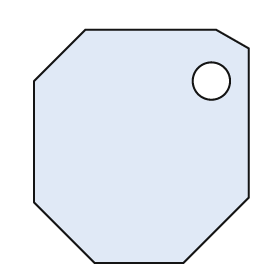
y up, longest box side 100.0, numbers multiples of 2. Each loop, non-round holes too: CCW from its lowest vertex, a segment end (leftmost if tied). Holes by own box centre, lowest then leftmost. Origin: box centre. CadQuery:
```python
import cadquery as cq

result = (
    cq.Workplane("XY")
    .moveTo(-20.0, -50.0)
    .lineTo(18.0, -50.0)
    .lineTo(46.0, -22.0)
    .lineTo(46.0, 42.0)
    .lineTo(32.0, 50.0)
    .lineTo(-24.0, 50.0)
    .lineTo(-46.0, 28.0)
    .lineTo(-46.0, -24.0)
    .close()
    .moveTo(30.0, 28.0)
    .circle(8.0)
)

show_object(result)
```